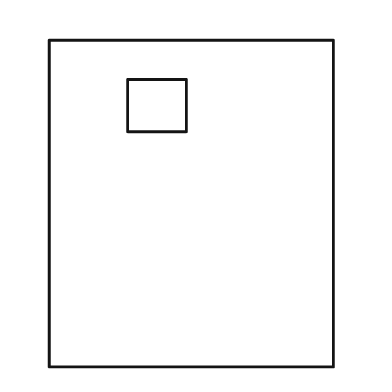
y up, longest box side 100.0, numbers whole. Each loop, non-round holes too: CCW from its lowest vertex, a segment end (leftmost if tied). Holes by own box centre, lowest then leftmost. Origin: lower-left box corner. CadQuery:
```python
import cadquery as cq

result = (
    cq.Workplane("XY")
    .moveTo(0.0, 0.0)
    .lineTo(87.0, 0.0)
    .lineTo(87.0, 100.0)
    .lineTo(0.0, 100.0)
    .close()
    .moveTo(24.0, 72.0)
    .lineTo(42.0, 72.0)
    .lineTo(42.0, 88.0)
    .lineTo(24.0, 88.0)
    .close()
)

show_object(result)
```